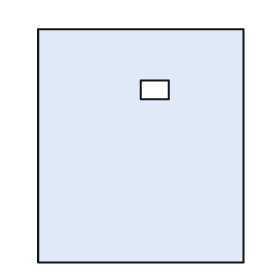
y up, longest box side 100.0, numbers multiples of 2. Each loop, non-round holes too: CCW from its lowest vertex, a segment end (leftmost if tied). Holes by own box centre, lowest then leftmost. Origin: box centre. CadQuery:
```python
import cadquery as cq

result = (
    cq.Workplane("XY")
    .moveTo(-44.0, -50.0)
    .lineTo(44.0, -50.0)
    .lineTo(44.0, 50.0)
    .lineTo(-44.0, 50.0)
    .close()
    .moveTo(0.0, 20.0)
    .lineTo(12.0, 20.0)
    .lineTo(12.0, 28.0)
    .lineTo(0.0, 28.0)
    .close()
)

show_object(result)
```